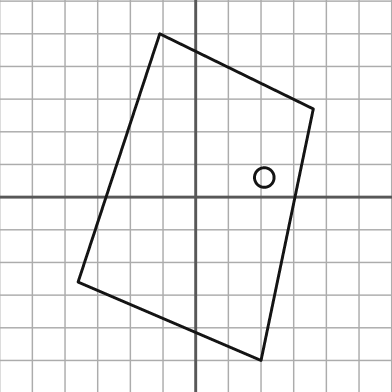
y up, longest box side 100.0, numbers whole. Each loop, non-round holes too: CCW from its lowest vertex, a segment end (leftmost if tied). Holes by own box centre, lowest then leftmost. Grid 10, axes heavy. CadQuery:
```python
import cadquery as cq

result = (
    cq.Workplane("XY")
    .moveTo(20.0, -50.0)
    .lineTo(36.0, 27.0)
    .lineTo(-11.0, 50.0)
    .lineTo(-36.0, -26.0)
    .close()
    .moveTo(21.0, 6.0)
    .circle(3.0)
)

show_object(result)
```